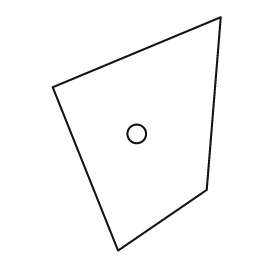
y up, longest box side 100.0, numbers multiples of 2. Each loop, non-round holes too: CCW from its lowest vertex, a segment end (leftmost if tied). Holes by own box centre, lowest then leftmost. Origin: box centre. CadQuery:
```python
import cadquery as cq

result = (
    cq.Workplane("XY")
    .moveTo(-8.0, -50.0)
    .lineTo(30.0, -24.0)
    .lineTo(36.0, 50.0)
    .lineTo(-36.0, 20.0)
    .close()
    .moveTo(0.0, 0.0)
    .circle(4.0)
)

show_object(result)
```